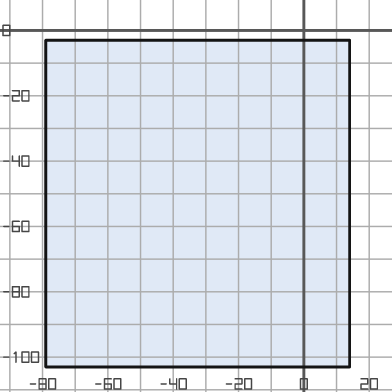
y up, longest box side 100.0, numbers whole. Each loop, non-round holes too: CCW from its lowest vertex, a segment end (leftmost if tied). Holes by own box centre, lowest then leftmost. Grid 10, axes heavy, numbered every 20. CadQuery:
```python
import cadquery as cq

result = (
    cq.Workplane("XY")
    .moveTo(-79.0, -103.0)
    .lineTo(14.0, -103.0)
    .lineTo(14.0, -3.0)
    .lineTo(-79.0, -3.0)
    .close()
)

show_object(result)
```